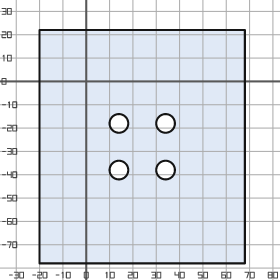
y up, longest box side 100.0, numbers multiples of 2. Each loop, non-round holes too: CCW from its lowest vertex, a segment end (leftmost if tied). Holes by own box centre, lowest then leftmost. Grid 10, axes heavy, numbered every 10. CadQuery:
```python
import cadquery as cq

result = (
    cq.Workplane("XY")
    .moveTo(-20.0, -78.0)
    .lineTo(68.0, -78.0)
    .lineTo(68.0, 22.0)
    .lineTo(-20.0, 22.0)
    .close()
    .moveTo(14.0, -38.0)
    .circle(4.0)
    .moveTo(34.0, -38.0)
    .circle(4.0)
    .moveTo(14.0, -18.0)
    .circle(4.0)
    .moveTo(34.0, -18.0)
    .circle(4.0)
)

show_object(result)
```